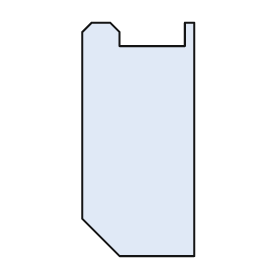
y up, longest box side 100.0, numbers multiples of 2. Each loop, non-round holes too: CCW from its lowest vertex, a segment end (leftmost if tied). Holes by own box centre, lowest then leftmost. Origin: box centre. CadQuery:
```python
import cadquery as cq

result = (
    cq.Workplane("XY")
    .moveTo(-8.0, -50.0)
    .lineTo(24.0, -50.0)
    .lineTo(24.0, 50.0)
    .lineTo(20.0, 50.0)
    .lineTo(20.0, 40.0)
    .lineTo(-8.0, 40.0)
    .lineTo(-8.0, 46.0)
    .lineTo(-12.0, 50.0)
    .lineTo(-20.0, 50.0)
    .lineTo(-24.0, 46.0)
    .lineTo(-24.0, -34.0)
    .close()
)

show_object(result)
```